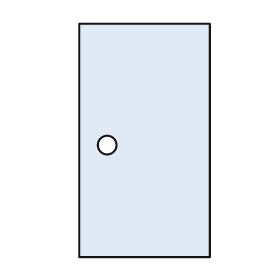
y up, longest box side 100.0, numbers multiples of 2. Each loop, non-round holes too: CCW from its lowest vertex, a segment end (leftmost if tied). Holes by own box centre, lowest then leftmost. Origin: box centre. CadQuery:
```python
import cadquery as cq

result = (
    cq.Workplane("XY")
    .moveTo(-28.0, -50.0)
    .lineTo(28.0, -50.0)
    .lineTo(28.0, 50.0)
    .lineTo(-28.0, 50.0)
    .close()
    .moveTo(-16.0, -2.0)
    .circle(4.0)
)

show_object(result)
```